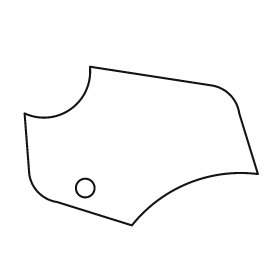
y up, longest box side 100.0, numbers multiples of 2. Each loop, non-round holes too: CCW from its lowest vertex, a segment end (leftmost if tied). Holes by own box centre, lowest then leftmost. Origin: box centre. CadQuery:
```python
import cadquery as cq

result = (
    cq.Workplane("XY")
    .moveTo(-4.0, -34.0)
    .threePointArc((20.0, -16.0), (50.0, -12.0))
    .lineTo(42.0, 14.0)
    .threePointArc((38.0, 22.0), (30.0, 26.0))
    .lineTo(-22.0, 34.0)
    .threePointArc((-30.0, 16.0), (-50.0, 14.0))
    .lineTo(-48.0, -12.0)
    .threePointArc((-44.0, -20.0), (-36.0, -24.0))
    .close()
    .moveTo(-24.0, -18.0)
    .circle(4.0)
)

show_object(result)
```